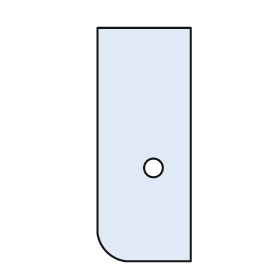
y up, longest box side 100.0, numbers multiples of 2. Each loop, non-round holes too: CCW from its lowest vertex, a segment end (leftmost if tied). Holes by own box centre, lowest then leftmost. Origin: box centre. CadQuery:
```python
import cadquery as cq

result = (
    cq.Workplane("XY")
    .moveTo(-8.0, -50.0)
    .lineTo(20.0, -50.0)
    .lineTo(20.0, 50.0)
    .lineTo(-20.0, 50.0)
    .lineTo(-20.0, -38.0)
    .threePointArc((-16.0, -46.0), (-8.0, -50.0))
    .close()
    .moveTo(4.0, -10.0)
    .circle(4.0)
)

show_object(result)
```